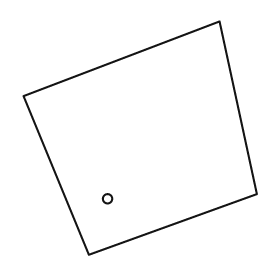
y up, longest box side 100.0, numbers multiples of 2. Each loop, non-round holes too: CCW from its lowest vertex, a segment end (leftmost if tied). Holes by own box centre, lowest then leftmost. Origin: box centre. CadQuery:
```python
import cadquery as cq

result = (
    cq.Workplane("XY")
    .moveTo(-22.0, -50.0)
    .lineTo(50.0, -24.0)
    .lineTo(34.0, 50.0)
    .lineTo(-50.0, 18.0)
    .close()
    .moveTo(-14.0, -26.0)
    .circle(2.0)
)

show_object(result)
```